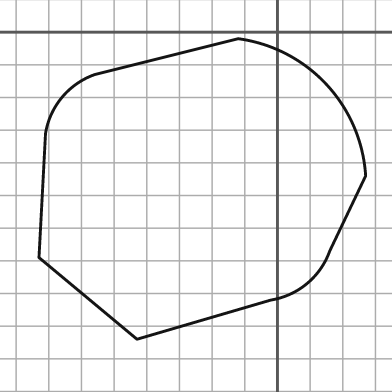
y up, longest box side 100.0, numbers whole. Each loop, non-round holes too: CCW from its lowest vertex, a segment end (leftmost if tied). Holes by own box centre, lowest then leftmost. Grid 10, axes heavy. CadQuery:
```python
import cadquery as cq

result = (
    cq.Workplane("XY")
    .moveTo(-43.0, -94.0)
    .lineTo(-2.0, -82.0)
    .threePointArc((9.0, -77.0), (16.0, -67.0))
    .lineTo(27.0, -44.0)
    .threePointArc((15.0, -16.0), (-12.0, -2.0))
    .lineTo(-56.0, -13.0)
    .threePointArc((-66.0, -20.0), (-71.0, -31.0))
    .lineTo(-73.0, -69.0)
    .close()
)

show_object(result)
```